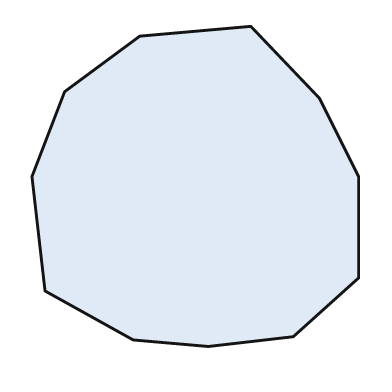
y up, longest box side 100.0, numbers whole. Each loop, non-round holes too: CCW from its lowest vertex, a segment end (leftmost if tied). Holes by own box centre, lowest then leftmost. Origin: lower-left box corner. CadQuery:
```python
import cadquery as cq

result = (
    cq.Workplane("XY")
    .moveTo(54.0, 0.0)
    .lineTo(80.0, 3.0)
    .lineTo(100.0, 21.0)
    .lineTo(100.0, 52.0)
    .lineTo(88.0, 76.0)
    .lineTo(67.0, 98.0)
    .lineTo(33.0, 95.0)
    .lineTo(10.0, 78.0)
    .lineTo(0.0, 52.0)
    .lineTo(4.0, 17.0)
    .lineTo(31.0, 2.0)
    .close()
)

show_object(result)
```